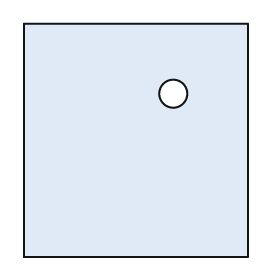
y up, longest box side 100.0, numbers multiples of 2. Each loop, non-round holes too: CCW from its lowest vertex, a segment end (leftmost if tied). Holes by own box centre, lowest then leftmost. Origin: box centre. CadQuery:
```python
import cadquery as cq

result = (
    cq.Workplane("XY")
    .moveTo(-48.0, -50.0)
    .lineTo(48.0, -50.0)
    .lineTo(48.0, 50.0)
    .lineTo(-48.0, 50.0)
    .close()
    .moveTo(16.0, 20.0)
    .circle(6.0)
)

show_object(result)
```